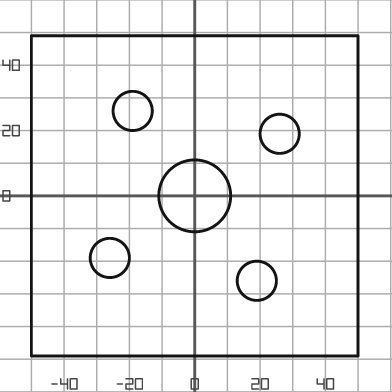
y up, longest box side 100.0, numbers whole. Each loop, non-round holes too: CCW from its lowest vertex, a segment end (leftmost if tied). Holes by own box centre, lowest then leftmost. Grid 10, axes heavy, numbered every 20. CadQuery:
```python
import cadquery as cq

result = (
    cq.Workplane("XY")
    .moveTo(-50.0, -49.0)
    .lineTo(50.0, -49.0)
    .lineTo(50.0, 49.0)
    .lineTo(-50.0, 49.0)
    .close()
    .moveTo(19.0, -26.0)
    .circle(6.0)
    .moveTo(-26.0, -19.0)
    .circle(6.0)
    .moveTo(0.0, 0.0)
    .circle(11.0)
    .moveTo(26.0, 19.0)
    .circle(6.0)
    .moveTo(-19.0, 26.0)
    .circle(6.0)
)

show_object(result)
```